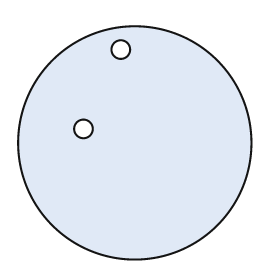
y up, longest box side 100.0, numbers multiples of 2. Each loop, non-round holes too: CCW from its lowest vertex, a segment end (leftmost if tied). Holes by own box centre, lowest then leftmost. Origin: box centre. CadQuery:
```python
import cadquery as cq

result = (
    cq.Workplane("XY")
    .moveTo(0.0, 0.0)
    .circle(50.0)
    .moveTo(-22.0, 6.0)
    .circle(4.0)
    .moveTo(-6.0, 40.0)
    .circle(4.0)
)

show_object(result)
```